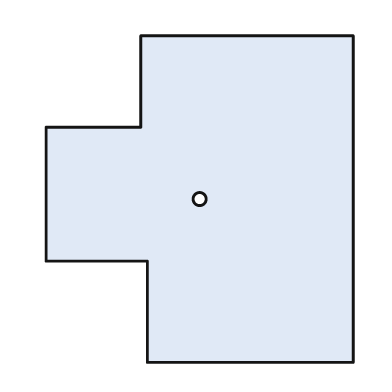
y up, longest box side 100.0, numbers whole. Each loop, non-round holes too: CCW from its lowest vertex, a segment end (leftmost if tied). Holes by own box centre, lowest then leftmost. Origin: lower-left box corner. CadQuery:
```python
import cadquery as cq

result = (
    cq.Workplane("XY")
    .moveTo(31.0, 0.0)
    .lineTo(94.0, 0.0)
    .lineTo(94.0, 100.0)
    .lineTo(29.0, 100.0)
    .lineTo(29.0, 72.0)
    .lineTo(0.0, 72.0)
    .lineTo(0.0, 31.0)
    .lineTo(31.0, 31.0)
    .close()
    .moveTo(47.0, 50.0)
    .circle(2.0)
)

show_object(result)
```